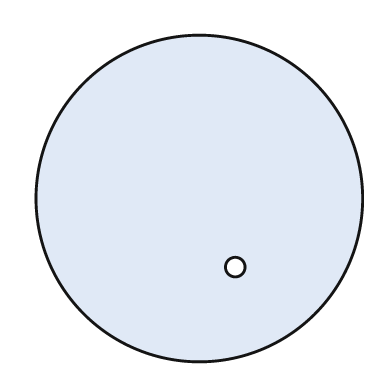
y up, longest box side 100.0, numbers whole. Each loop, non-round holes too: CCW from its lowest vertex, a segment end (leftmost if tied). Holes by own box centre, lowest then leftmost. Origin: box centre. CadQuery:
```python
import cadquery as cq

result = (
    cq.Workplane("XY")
    .moveTo(0.0, 0.0)
    .circle(50.0)
    .moveTo(11.0, -21.0)
    .circle(3.0)
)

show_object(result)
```